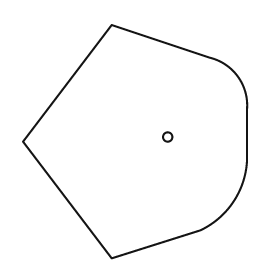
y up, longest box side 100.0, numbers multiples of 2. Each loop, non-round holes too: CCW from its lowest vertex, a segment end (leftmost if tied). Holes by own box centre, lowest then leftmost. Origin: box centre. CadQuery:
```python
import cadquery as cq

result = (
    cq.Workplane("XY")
    .moveTo(-10.0, -50.0)
    .lineTo(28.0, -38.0)
    .threePointArc((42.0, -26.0), (48.0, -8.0))
    .lineTo(48.0, 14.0)
    .threePointArc((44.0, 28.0), (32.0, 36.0))
    .lineTo(-10.0, 50.0)
    .lineTo(-48.0, 0.0)
    .close()
    .moveTo(14.0, 2.0)
    .circle(2.0)
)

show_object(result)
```